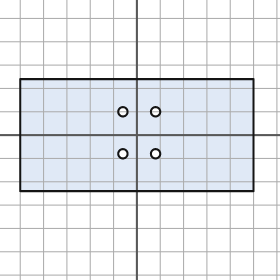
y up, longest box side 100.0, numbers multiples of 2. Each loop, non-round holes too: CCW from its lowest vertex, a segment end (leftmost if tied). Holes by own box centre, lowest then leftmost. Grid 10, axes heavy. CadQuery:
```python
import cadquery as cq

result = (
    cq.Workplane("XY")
    .moveTo(-50.0, -24.0)
    .lineTo(50.0, -24.0)
    .lineTo(50.0, 24.0)
    .lineTo(-50.0, 24.0)
    .close()
    .moveTo(-6.0, -8.0)
    .circle(2.0)
    .moveTo(8.0, -8.0)
    .circle(2.0)
    .moveTo(-6.0, 10.0)
    .circle(2.0)
    .moveTo(8.0, 10.0)
    .circle(2.0)
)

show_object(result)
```